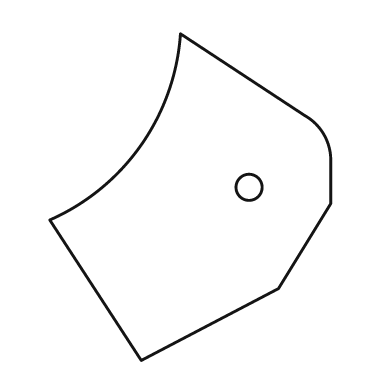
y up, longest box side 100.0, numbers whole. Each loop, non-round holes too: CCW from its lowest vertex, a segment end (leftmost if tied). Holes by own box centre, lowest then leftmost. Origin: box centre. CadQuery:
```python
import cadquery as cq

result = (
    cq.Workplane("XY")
    .moveTo(-15.0, -50.0)
    .lineTo(27.0, -28.0)
    .lineTo(43.0, -2.0)
    .lineTo(43.0, 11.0)
    .threePointArc((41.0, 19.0), (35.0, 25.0))
    .lineTo(-3.0, 50.0)
    .threePointArc((-15.0, 16.0), (-43.0, -7.0))
    .close()
    .moveTo(18.0, 3.0)
    .circle(4.0)
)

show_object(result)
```